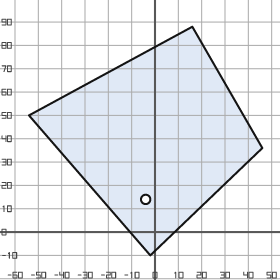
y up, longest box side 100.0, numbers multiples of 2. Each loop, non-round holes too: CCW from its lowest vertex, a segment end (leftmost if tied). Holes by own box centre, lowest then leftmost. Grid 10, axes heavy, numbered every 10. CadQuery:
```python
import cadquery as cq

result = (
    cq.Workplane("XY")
    .moveTo(-2.0, -10.0)
    .lineTo(46.0, 36.0)
    .lineTo(16.0, 88.0)
    .lineTo(-54.0, 50.0)
    .close()
    .moveTo(-4.0, 14.0)
    .circle(2.0)
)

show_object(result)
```